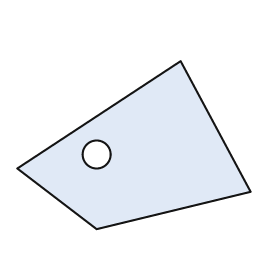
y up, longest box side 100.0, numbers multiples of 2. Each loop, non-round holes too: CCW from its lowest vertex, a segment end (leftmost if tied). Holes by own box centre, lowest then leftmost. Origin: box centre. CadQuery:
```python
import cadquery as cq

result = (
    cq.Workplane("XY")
    .moveTo(-16.0, -36.0)
    .lineTo(50.0, -20.0)
    .lineTo(20.0, 36.0)
    .lineTo(-50.0, -10.0)
    .close()
    .moveTo(-16.0, -4.0)
    .circle(6.0)
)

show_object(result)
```